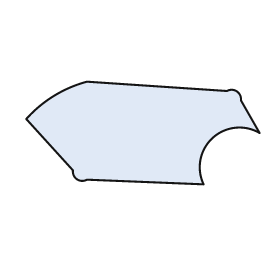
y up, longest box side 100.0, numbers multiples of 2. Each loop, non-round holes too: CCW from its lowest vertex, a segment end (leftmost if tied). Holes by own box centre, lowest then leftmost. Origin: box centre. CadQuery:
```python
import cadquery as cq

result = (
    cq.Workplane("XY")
    .moveTo(26.0, -22.0)
    .threePointArc((30.0, -2.0), (50.0, 0.0))
    .lineTo(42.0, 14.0)
    .threePointArc((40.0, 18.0), (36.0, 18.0))
    .lineTo(-24.0, 22.0)
    .threePointArc((-38.0, 16.0), (-50.0, 6.0))
    .lineTo(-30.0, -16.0)
    .threePointArc((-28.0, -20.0), (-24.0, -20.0))
    .close()
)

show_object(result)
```